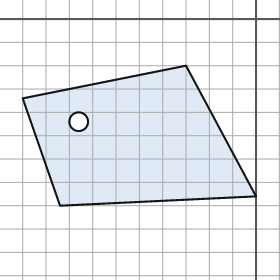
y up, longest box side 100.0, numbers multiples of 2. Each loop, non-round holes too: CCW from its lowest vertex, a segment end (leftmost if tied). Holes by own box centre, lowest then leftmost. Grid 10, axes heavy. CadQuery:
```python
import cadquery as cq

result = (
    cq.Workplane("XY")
    .moveTo(-84.0, -80.0)
    .lineTo(0.0, -76.0)
    .lineTo(-30.0, -20.0)
    .lineTo(-100.0, -34.0)
    .close()
    .moveTo(-76.0, -44.0)
    .circle(4.0)
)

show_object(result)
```